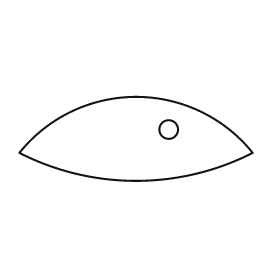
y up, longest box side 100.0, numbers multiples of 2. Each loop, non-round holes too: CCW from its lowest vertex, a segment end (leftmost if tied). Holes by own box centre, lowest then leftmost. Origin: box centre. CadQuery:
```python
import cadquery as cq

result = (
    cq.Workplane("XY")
    .moveTo(-50.0, -6.0)
    .threePointArc((0.0, -18.0), (50.0, -6.0))
    .threePointArc((0.0, 18.0), (-50.0, -6.0))
    .close()
    .moveTo(14.0, 4.0)
    .circle(4.0)
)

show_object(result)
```